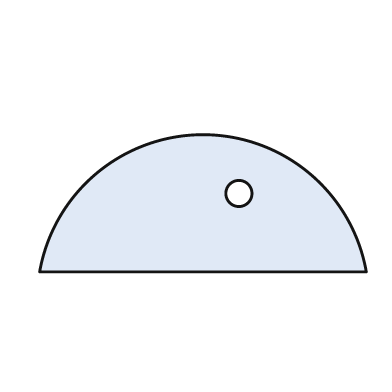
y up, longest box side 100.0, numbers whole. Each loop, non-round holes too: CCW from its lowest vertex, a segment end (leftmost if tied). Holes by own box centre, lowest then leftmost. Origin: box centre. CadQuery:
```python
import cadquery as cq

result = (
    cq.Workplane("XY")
    .moveTo(-50.0, -21.0)
    .lineTo(50.0, -21.0)
    .threePointArc((0.0, 21.0), (-50.0, -21.0))
    .close()
    .moveTo(11.0, 3.0)
    .circle(4.0)
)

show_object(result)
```